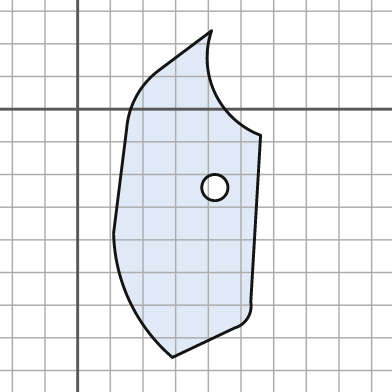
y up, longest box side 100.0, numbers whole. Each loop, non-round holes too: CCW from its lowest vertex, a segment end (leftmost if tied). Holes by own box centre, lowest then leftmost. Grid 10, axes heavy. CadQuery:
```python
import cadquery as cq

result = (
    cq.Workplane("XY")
    .moveTo(29.0, -76.0)
    .lineTo(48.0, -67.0)
    .threePointArc((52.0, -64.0), (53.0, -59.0))
    .lineTo(56.0, -8.0)
    .threePointArc((42.0, 5.0), (41.0, 24.0))
    .lineTo(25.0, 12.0)
    .threePointArc((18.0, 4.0), (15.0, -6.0))
    .lineTo(11.0, -38.0)
    .threePointArc((16.0, -59.0), (29.0, -76.0))
    .close()
    .moveTo(42.0, -24.0)
    .circle(4.0)
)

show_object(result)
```